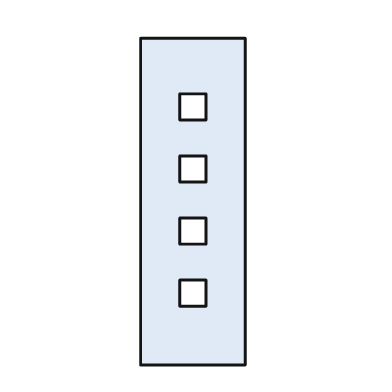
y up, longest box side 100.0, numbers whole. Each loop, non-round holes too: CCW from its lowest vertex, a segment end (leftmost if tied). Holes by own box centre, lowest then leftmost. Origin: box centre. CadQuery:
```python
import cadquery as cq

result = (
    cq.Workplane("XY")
    .moveTo(-16.0, -50.0)
    .lineTo(16.0, -50.0)
    .lineTo(16.0, 50.0)
    .lineTo(-16.0, 50.0)
    .close()
    .moveTo(-4.0, -32.0)
    .lineTo(4.0, -32.0)
    .lineTo(4.0, -24.0)
    .lineTo(-4.0, -24.0)
    .close()
    .moveTo(-4.0, -13.0)
    .lineTo(4.0, -13.0)
    .lineTo(4.0, -5.0)
    .lineTo(-4.0, -5.0)
    .close()
    .moveTo(-4.0, 6.0)
    .lineTo(4.0, 6.0)
    .lineTo(4.0, 14.0)
    .lineTo(-4.0, 14.0)
    .close()
    .moveTo(-4.0, 25.0)
    .lineTo(4.0, 25.0)
    .lineTo(4.0, 33.0)
    .lineTo(-4.0, 33.0)
    .close()
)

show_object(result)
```